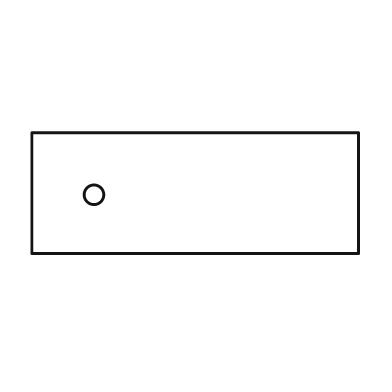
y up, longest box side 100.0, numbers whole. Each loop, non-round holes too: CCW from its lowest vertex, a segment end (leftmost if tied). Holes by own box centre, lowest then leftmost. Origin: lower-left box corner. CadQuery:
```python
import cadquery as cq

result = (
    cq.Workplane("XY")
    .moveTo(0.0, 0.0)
    .lineTo(100.0, 0.0)
    .lineTo(100.0, 37.0)
    .lineTo(0.0, 37.0)
    .close()
    .moveTo(19.0, 18.0)
    .circle(3.0)
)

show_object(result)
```